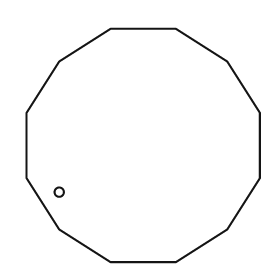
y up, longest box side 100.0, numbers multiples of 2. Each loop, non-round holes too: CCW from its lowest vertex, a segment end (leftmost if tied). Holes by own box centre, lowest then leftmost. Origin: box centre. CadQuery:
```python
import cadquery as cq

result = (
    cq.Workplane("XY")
    .moveTo(-14.0, -50.0)
    .lineTo(14.0, -50.0)
    .lineTo(36.0, -36.0)
    .lineTo(50.0, -14.0)
    .lineTo(50.0, 14.0)
    .lineTo(36.0, 36.0)
    .lineTo(14.0, 50.0)
    .lineTo(-14.0, 50.0)
    .lineTo(-36.0, 36.0)
    .lineTo(-50.0, 14.0)
    .lineTo(-50.0, -14.0)
    .lineTo(-36.0, -36.0)
    .close()
    .moveTo(-36.0, -20.0)
    .circle(2.0)
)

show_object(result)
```